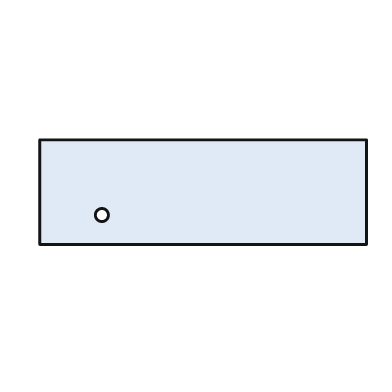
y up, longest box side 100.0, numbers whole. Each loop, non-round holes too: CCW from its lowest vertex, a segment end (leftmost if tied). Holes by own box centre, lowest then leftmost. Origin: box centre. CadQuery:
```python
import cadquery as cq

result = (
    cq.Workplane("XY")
    .moveTo(-50.0, -16.0)
    .lineTo(50.0, -16.0)
    .lineTo(50.0, 16.0)
    .lineTo(-50.0, 16.0)
    .close()
    .moveTo(-31.0, -7.0)
    .circle(2.0)
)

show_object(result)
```